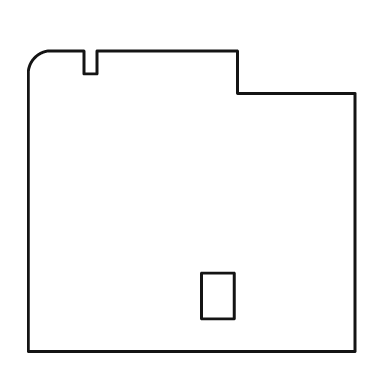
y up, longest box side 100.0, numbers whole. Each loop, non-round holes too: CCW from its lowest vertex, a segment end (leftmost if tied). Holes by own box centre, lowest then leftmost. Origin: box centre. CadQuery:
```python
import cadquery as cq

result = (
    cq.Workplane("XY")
    .moveTo(-50.0, -46.0)
    .lineTo(50.0, -46.0)
    .lineTo(50.0, 33.0)
    .lineTo(14.0, 33.0)
    .lineTo(14.0, 46.0)
    .lineTo(-29.0, 46.0)
    .lineTo(-29.0, 39.0)
    .lineTo(-33.0, 39.0)
    .lineTo(-33.0, 46.0)
    .lineTo(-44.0, 46.0)
    .threePointArc((-48.0, 44.0), (-50.0, 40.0))
    .close()
    .moveTo(3.0, -36.0)
    .lineTo(13.0, -36.0)
    .lineTo(13.0, -22.0)
    .lineTo(3.0, -22.0)
    .close()
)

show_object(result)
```